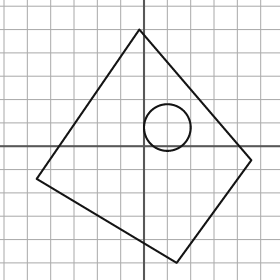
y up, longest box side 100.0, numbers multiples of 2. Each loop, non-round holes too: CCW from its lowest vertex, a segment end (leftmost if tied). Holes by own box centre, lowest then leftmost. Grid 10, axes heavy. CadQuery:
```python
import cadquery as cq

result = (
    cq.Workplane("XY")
    .moveTo(14.0, -50.0)
    .lineTo(46.0, -6.0)
    .lineTo(-2.0, 50.0)
    .lineTo(-46.0, -14.0)
    .close()
    .moveTo(10.0, 8.0)
    .circle(10.0)
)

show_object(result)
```